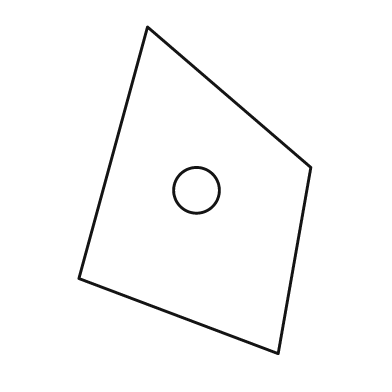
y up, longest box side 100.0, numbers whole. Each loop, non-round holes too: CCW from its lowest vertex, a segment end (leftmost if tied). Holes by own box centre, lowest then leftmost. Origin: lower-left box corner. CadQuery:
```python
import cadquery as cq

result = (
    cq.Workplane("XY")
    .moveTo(61.0, 0.0)
    .lineTo(71.0, 57.0)
    .lineTo(21.0, 100.0)
    .lineTo(0.0, 23.0)
    .close()
    .moveTo(36.0, 50.0)
    .circle(7.0)
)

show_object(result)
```